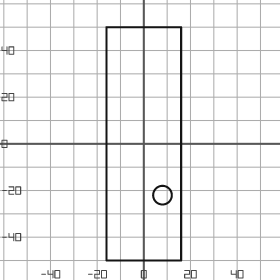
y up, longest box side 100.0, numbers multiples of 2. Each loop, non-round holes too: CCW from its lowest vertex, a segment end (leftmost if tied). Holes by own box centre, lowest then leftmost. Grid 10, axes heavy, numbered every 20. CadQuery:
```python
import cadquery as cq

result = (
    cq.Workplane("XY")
    .moveTo(-16.0, -50.0)
    .lineTo(16.0, -50.0)
    .lineTo(16.0, 50.0)
    .lineTo(-16.0, 50.0)
    .close()
    .moveTo(8.0, -22.0)
    .circle(4.0)
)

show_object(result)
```